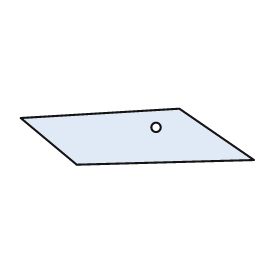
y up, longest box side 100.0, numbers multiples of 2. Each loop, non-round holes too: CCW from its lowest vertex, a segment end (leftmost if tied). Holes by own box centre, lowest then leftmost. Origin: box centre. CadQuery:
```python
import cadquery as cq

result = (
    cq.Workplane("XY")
    .moveTo(-26.0, -12.0)
    .lineTo(50.0, -10.0)
    .lineTo(18.0, 12.0)
    .lineTo(-50.0, 8.0)
    .close()
    .moveTo(8.0, 4.0)
    .circle(2.0)
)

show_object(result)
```